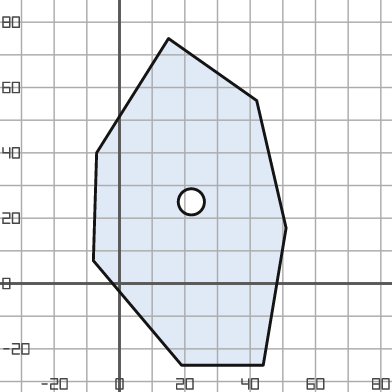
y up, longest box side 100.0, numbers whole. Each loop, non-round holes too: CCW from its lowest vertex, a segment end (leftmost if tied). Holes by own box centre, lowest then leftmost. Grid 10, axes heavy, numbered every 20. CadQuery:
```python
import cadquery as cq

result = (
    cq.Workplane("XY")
    .moveTo(19.0, -25.0)
    .lineTo(44.0, -25.0)
    .lineTo(51.0, 17.0)
    .lineTo(42.0, 56.0)
    .lineTo(15.0, 75.0)
    .lineTo(-7.0, 40.0)
    .lineTo(-8.0, 7.0)
    .close()
    .moveTo(22.0, 25.0)
    .circle(4.0)
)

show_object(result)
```